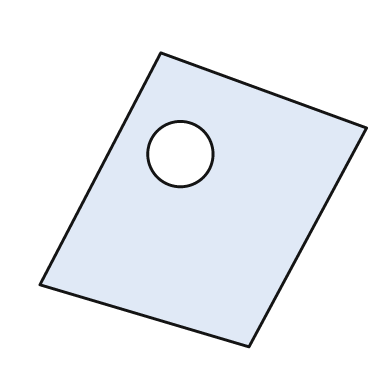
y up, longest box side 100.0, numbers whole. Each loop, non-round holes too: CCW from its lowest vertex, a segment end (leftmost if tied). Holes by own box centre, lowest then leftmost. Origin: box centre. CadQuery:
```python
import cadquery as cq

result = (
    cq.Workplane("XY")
    .moveTo(14.0, -45.0)
    .lineTo(50.0, 22.0)
    .lineTo(-13.0, 45.0)
    .lineTo(-50.0, -26.0)
    .close()
    .moveTo(-7.0, 14.0)
    .circle(10.0)
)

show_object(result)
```